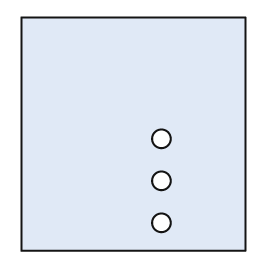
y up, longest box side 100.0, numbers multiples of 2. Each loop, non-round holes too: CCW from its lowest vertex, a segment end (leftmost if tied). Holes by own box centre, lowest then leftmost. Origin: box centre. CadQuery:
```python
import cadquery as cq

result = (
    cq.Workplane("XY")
    .moveTo(-48.0, -50.0)
    .lineTo(48.0, -50.0)
    .lineTo(48.0, 50.0)
    .lineTo(-48.0, 50.0)
    .close()
    .moveTo(12.0, -38.0)
    .circle(4.0)
    .moveTo(12.0, -20.0)
    .circle(4.0)
    .moveTo(12.0, -2.0)
    .circle(4.0)
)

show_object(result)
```